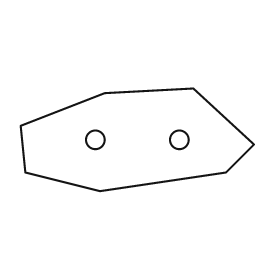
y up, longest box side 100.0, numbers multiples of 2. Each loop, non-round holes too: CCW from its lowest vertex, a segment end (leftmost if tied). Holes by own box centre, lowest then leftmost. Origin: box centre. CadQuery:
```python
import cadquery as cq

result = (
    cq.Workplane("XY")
    .moveTo(-16.0, -22.0)
    .lineTo(38.0, -14.0)
    .lineTo(50.0, -2.0)
    .lineTo(24.0, 22.0)
    .lineTo(-14.0, 20.0)
    .lineTo(-50.0, 6.0)
    .lineTo(-48.0, -14.0)
    .close()
    .moveTo(-18.0, 0.0)
    .circle(4.0)
    .moveTo(18.0, 0.0)
    .circle(4.0)
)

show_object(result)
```